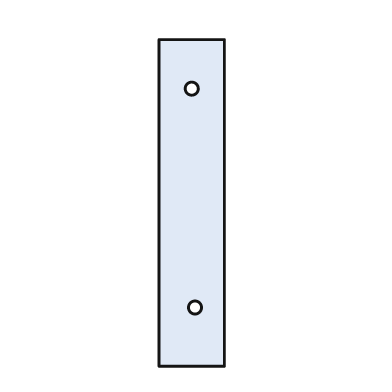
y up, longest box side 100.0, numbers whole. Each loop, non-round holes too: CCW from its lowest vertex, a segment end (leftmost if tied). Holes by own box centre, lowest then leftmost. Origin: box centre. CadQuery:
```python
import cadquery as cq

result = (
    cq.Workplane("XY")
    .moveTo(-10.0, -50.0)
    .lineTo(10.0, -50.0)
    .lineTo(10.0, 50.0)
    .lineTo(-10.0, 50.0)
    .close()
    .moveTo(1.0, -32.0)
    .circle(2.0)
    .moveTo(0.0, 35.0)
    .circle(2.0)
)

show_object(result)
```